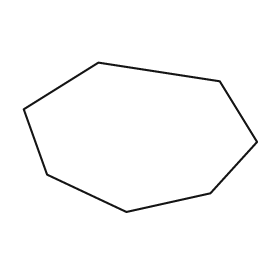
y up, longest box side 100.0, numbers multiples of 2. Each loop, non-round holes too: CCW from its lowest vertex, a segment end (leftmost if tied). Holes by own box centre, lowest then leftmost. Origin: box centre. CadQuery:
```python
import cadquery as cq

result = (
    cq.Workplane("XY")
    .moveTo(-6.0, -32.0)
    .lineTo(30.0, -24.0)
    .lineTo(50.0, -2.0)
    .lineTo(34.0, 24.0)
    .lineTo(-18.0, 32.0)
    .lineTo(-50.0, 12.0)
    .lineTo(-40.0, -16.0)
    .close()
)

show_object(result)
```